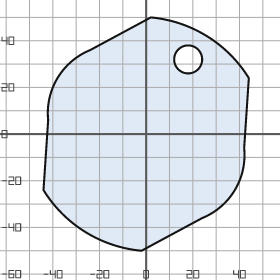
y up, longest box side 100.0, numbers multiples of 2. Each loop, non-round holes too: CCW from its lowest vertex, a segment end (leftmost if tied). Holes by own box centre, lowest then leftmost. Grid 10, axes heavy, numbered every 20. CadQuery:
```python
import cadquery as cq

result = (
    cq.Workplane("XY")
    .moveTo(-2.0, -50.0)
    .lineTo(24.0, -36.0)
    .threePointArc((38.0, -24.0), (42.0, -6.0))
    .lineTo(44.0, 24.0)
    .threePointArc((26.0, 42.0), (2.0, 50.0))
    .lineTo(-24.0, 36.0)
    .threePointArc((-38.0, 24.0), (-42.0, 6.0))
    .lineTo(-44.0, -24.0)
    .threePointArc((-26.0, -42.0), (-2.0, -50.0))
    .close()
    .moveTo(18.0, 32.0)
    .circle(6.0)
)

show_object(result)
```